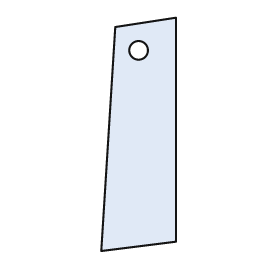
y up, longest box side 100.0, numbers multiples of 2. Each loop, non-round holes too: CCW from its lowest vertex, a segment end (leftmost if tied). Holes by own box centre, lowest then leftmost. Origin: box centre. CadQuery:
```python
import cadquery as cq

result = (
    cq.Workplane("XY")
    .moveTo(-16.0, -50.0)
    .lineTo(16.0, -46.0)
    .lineTo(16.0, 50.0)
    .lineTo(-10.0, 46.0)
    .close()
    .moveTo(0.0, 36.0)
    .circle(4.0)
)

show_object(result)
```